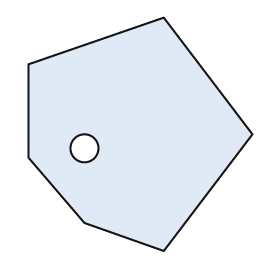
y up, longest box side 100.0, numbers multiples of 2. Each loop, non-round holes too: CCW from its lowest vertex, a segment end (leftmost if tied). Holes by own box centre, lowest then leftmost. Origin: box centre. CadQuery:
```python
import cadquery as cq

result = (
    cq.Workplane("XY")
    .moveTo(10.0, -50.0)
    .lineTo(48.0, 0.0)
    .lineTo(10.0, 50.0)
    .lineTo(-48.0, 30.0)
    .lineTo(-48.0, -10.0)
    .lineTo(-24.0, -38.0)
    .close()
    .moveTo(-24.0, -6.0)
    .circle(6.0)
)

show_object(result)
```